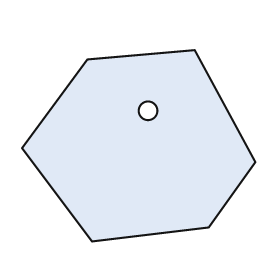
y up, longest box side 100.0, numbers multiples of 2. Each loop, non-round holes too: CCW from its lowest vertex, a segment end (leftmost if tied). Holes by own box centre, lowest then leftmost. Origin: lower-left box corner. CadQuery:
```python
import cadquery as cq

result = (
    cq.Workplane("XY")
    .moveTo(30.0, 0.0)
    .lineTo(80.0, 6.0)
    .lineTo(100.0, 34.0)
    .lineTo(74.0, 82.0)
    .lineTo(28.0, 78.0)
    .lineTo(0.0, 40.0)
    .close()
    .moveTo(54.0, 56.0)
    .circle(4.0)
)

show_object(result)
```